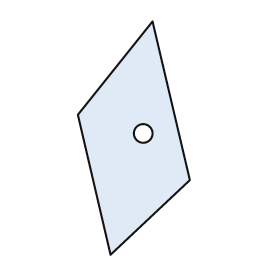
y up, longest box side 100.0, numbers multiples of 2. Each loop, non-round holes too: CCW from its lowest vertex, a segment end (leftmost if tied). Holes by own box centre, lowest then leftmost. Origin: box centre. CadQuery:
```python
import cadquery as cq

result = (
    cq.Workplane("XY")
    .moveTo(-10.0, -50.0)
    .lineTo(24.0, -18.0)
    .lineTo(8.0, 50.0)
    .lineTo(-24.0, 10.0)
    .close()
    .moveTo(4.0, 2.0)
    .circle(4.0)
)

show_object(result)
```